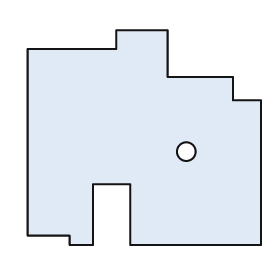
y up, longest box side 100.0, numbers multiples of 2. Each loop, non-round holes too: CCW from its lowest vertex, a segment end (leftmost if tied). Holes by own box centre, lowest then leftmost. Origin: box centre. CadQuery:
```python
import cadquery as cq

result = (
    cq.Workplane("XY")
    .moveTo(-32.0, -46.0)
    .lineTo(-22.0, -46.0)
    .lineTo(-22.0, -20.0)
    .lineTo(-6.0, -20.0)
    .lineTo(-6.0, -46.0)
    .lineTo(50.0, -46.0)
    .lineTo(50.0, 16.0)
    .lineTo(38.0, 16.0)
    .lineTo(38.0, 26.0)
    .lineTo(10.0, 26.0)
    .lineTo(10.0, 46.0)
    .lineTo(-12.0, 46.0)
    .lineTo(-12.0, 38.0)
    .lineTo(-50.0, 38.0)
    .lineTo(-50.0, -42.0)
    .lineTo(-32.0, -42.0)
    .close()
    .moveTo(18.0, -6.0)
    .circle(4.0)
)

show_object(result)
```